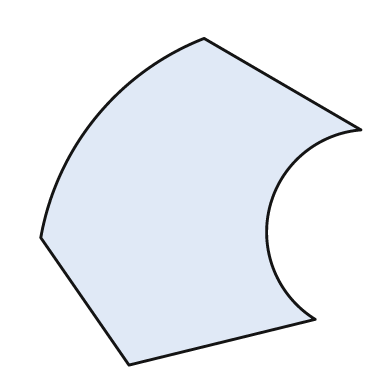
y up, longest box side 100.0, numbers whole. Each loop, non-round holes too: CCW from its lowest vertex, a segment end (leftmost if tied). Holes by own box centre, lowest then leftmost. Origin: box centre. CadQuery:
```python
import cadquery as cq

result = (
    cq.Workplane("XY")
    .moveTo(-22.0, -50.0)
    .lineTo(35.0, -36.0)
    .threePointArc((21.0, -2.0), (49.0, 22.0))
    .lineTo(1.0, 50.0)
    .threePointArc((-32.0, 26.0), (-49.0, -11.0))
    .close()
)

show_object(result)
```